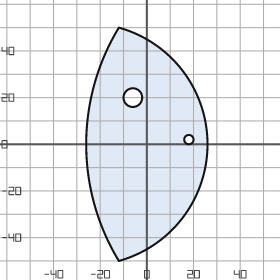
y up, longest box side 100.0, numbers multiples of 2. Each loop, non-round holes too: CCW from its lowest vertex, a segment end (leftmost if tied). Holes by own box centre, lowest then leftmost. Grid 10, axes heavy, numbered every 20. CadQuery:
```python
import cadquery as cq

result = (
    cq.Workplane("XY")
    .moveTo(-12.0, -50.0)
    .threePointArc((26.0, 0.0), (-12.0, 50.0))
    .threePointArc((-26.0, 0.0), (-12.0, -50.0))
    .close()
    .moveTo(18.0, 2.0)
    .circle(2.0)
    .moveTo(-6.0, 20.0)
    .circle(4.0)
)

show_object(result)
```